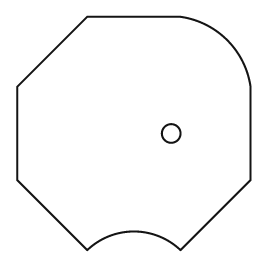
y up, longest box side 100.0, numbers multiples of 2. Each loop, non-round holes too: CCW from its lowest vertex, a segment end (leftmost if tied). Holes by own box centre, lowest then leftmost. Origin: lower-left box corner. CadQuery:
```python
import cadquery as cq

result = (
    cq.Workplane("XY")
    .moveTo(30.0, 0.0)
    .threePointArc((50.0, 8.0), (70.0, 0.0))
    .lineTo(100.0, 30.0)
    .lineTo(100.0, 70.0)
    .threePointArc((90.0, 90.0), (70.0, 100.0))
    .lineTo(30.0, 100.0)
    .lineTo(0.0, 70.0)
    .lineTo(0.0, 30.0)
    .close()
    .moveTo(66.0, 50.0)
    .circle(4.0)
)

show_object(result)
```